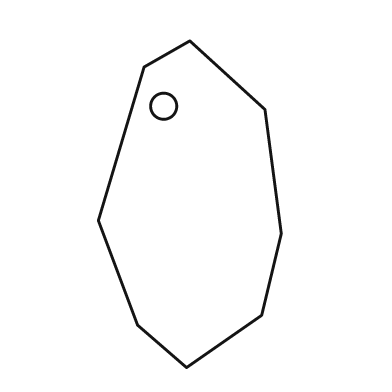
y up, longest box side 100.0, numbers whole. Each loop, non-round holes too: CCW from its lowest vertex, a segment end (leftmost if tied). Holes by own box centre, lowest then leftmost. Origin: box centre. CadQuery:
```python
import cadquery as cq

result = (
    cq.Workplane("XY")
    .moveTo(-1.0, -50.0)
    .lineTo(22.0, -34.0)
    .lineTo(28.0, -9.0)
    .lineTo(23.0, 29.0)
    .lineTo(0.0, 50.0)
    .lineTo(-14.0, 42.0)
    .lineTo(-28.0, -5.0)
    .lineTo(-16.0, -37.0)
    .close()
    .moveTo(-8.0, 30.0)
    .circle(4.0)
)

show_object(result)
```